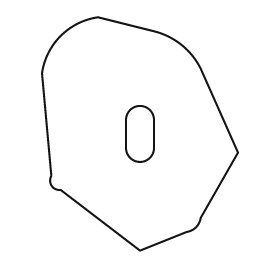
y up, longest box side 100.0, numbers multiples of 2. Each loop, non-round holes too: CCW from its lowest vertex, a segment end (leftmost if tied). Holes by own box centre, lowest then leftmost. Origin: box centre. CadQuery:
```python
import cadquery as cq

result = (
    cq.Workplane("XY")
    .moveTo(0.0, -50.0)
    .lineTo(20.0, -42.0)
    .threePointArc((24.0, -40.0), (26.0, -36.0))
    .lineTo(42.0, -8.0)
    .lineTo(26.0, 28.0)
    .threePointArc((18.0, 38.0), (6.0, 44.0))
    .lineTo(-18.0, 50.0)
    .threePointArc((-34.0, 42.0), (-42.0, 26.0))
    .lineTo(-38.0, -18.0)
    .threePointArc((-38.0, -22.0), (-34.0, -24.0))
    .close()
    .moveTo(-6.0, -6.0)
    .threePointArc((0.0, -12.0), (6.0, -6.0))
    .lineTo(6.0, 6.0)
    .threePointArc((0.0, 12.0), (-6.0, 6.0))
    .close()
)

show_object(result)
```